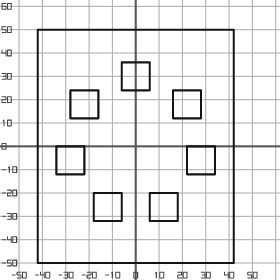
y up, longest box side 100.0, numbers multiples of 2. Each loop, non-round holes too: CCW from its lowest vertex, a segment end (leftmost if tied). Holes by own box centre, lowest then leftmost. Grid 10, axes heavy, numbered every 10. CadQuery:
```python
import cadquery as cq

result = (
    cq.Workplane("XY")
    .moveTo(-42.0, -50.0)
    .lineTo(42.0, -50.0)
    .lineTo(42.0, 50.0)
    .lineTo(-42.0, 50.0)
    .close()
    .moveTo(-18.0, -32.0)
    .lineTo(-6.0, -32.0)
    .lineTo(-6.0, -20.0)
    .lineTo(-18.0, -20.0)
    .close()
    .moveTo(6.0, -32.0)
    .lineTo(18.0, -32.0)
    .lineTo(18.0, -20.0)
    .lineTo(6.0, -20.0)
    .close()
    .moveTo(-34.0, -12.0)
    .lineTo(-22.0, -12.0)
    .lineTo(-22.0, 0.0)
    .lineTo(-34.0, 0.0)
    .close()
    .moveTo(22.0, -12.0)
    .lineTo(34.0, -12.0)
    .lineTo(34.0, 0.0)
    .lineTo(22.0, 0.0)
    .close()
    .moveTo(-28.0, 12.0)
    .lineTo(-16.0, 12.0)
    .lineTo(-16.0, 24.0)
    .lineTo(-28.0, 24.0)
    .close()
    .moveTo(16.0, 12.0)
    .lineTo(28.0, 12.0)
    .lineTo(28.0, 24.0)
    .lineTo(16.0, 24.0)
    .close()
    .moveTo(-6.0, 24.0)
    .lineTo(6.0, 24.0)
    .lineTo(6.0, 36.0)
    .lineTo(-6.0, 36.0)
    .close()
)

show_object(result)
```